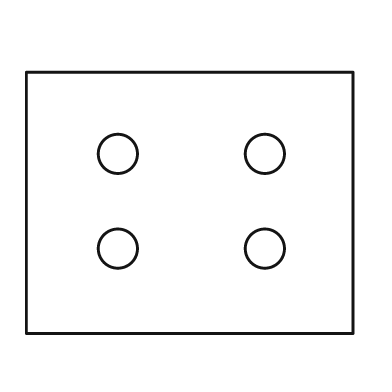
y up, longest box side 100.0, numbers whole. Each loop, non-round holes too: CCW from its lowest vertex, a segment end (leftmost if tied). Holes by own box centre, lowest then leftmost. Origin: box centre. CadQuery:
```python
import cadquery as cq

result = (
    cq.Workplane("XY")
    .moveTo(-50.0, -40.0)
    .lineTo(50.0, -40.0)
    .lineTo(50.0, 40.0)
    .lineTo(-50.0, 40.0)
    .close()
    .moveTo(-22.0, -14.0)
    .circle(6.0)
    .moveTo(23.0, -14.0)
    .circle(6.0)
    .moveTo(-22.0, 15.0)
    .circle(6.0)
    .moveTo(23.0, 15.0)
    .circle(6.0)
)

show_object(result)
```